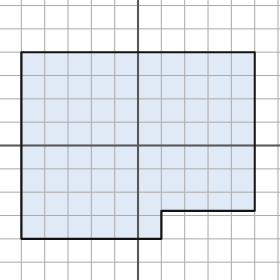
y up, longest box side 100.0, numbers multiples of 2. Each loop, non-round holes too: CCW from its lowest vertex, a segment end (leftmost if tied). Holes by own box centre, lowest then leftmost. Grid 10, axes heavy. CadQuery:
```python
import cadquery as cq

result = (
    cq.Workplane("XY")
    .moveTo(-50.0, -40.0)
    .lineTo(10.0, -40.0)
    .lineTo(10.0, -28.0)
    .lineTo(50.0, -28.0)
    .lineTo(50.0, 40.0)
    .lineTo(-50.0, 40.0)
    .close()
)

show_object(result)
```